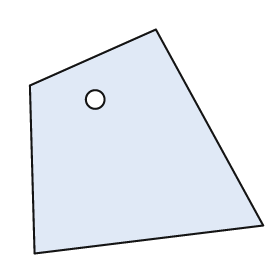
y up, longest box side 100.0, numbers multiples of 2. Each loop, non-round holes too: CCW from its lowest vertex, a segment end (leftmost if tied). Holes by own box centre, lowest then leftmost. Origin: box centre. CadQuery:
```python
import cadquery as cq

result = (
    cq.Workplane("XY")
    .moveTo(-48.0, -48.0)
    .lineTo(50.0, -36.0)
    .lineTo(4.0, 48.0)
    .lineTo(-50.0, 24.0)
    .close()
    .moveTo(-22.0, 18.0)
    .circle(4.0)
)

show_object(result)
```